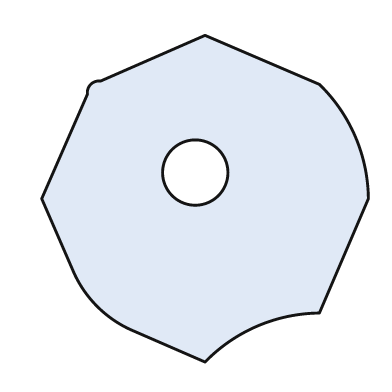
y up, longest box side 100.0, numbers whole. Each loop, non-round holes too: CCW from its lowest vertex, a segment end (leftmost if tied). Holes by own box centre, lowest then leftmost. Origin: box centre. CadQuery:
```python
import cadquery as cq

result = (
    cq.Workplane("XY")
    .moveTo(0.0, -50.0)
    .threePointArc((16.0, -39.0), (35.0, -35.0))
    .lineTo(50.0, 0.0)
    .threePointArc((46.0, 19.0), (35.0, 35.0))
    .lineTo(0.0, 50.0)
    .lineTo(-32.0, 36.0)
    .threePointArc((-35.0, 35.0), (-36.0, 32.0))
    .lineTo(-50.0, 0.0)
    .lineTo(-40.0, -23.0)
    .threePointArc((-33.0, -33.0), (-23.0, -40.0))
    .close()
    .moveTo(-3.0, 8.0)
    .circle(10.0)
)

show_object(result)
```